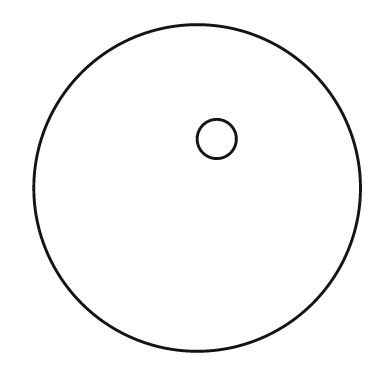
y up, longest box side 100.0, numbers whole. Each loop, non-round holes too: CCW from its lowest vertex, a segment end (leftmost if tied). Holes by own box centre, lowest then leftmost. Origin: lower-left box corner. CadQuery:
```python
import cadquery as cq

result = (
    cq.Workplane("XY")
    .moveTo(50.0, 50.0)
    .circle(50.0)
    .moveTo(56.0, 65.0)
    .circle(6.0)
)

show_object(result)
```